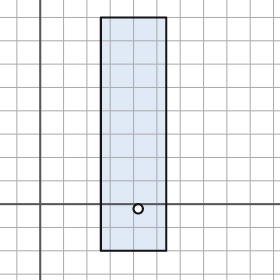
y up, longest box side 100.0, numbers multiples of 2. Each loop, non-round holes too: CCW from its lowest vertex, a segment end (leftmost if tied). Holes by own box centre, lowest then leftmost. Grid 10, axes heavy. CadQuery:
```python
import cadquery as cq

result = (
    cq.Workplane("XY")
    .moveTo(26.0, -20.0)
    .lineTo(54.0, -20.0)
    .lineTo(54.0, 80.0)
    .lineTo(26.0, 80.0)
    .close()
    .moveTo(42.0, -2.0)
    .circle(2.0)
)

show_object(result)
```